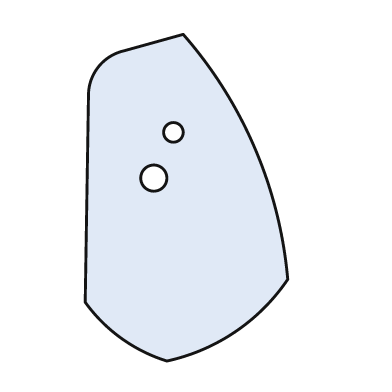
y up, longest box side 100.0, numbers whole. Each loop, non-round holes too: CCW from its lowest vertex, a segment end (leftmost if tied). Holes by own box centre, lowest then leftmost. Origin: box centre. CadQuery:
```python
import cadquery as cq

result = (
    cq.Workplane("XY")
    .moveTo(-6.0, -50.0)
    .threePointArc((15.0, -41.0), (31.0, -25.0))
    .threePointArc((21.0, 15.0), (-1.0, 50.0))
    .lineTo(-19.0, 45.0)
    .threePointArc((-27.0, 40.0), (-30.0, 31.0))
    .lineTo(-31.0, -32.0)
    .threePointArc((-20.0, -43.0), (-6.0, -50.0))
    .close()
    .moveTo(-10.0, 6.0)
    .circle(4.0)
    .moveTo(-4.0, 20.0)
    .circle(3.0)
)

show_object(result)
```